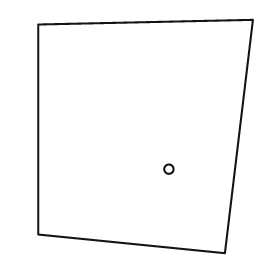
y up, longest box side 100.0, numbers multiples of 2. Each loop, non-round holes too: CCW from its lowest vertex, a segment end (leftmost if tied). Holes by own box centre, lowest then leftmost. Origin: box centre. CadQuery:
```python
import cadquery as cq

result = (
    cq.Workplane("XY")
    .moveTo(34.0, -50.0)
    .lineTo(46.0, 50.0)
    .lineTo(-46.0, 48.0)
    .lineTo(-46.0, -42.0)
    .close()
    .moveTo(10.0, -14.0)
    .circle(2.0)
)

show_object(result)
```